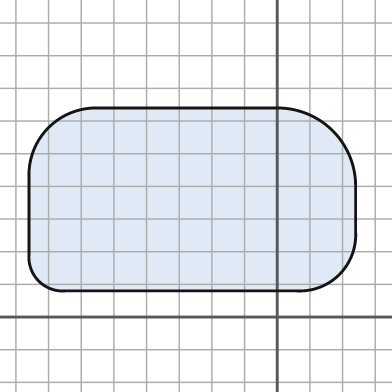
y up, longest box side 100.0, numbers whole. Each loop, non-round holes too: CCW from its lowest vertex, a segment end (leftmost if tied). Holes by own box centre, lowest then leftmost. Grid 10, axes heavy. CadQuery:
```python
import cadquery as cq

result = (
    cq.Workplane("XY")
    .moveTo(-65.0, 8.0)
    .lineTo(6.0, 8.0)
    .threePointArc((19.0, 13.0), (24.0, 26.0))
    .lineTo(24.0, 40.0)
    .threePointArc((17.0, 57.0), (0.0, 64.0))
    .lineTo(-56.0, 64.0)
    .threePointArc((-70.0, 58.0), (-76.0, 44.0))
    .lineTo(-76.0, 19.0)
    .threePointArc((-73.0, 11.0), (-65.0, 8.0))
    .close()
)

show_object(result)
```